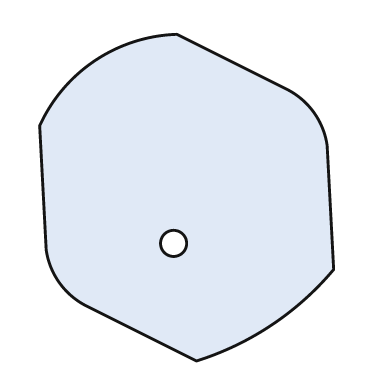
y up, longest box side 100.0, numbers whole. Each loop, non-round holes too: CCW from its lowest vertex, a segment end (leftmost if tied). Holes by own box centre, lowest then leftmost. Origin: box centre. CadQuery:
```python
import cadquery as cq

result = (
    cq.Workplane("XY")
    .moveTo(3.0, -50.0)
    .threePointArc((26.0, -39.0), (45.0, -22.0))
    .lineTo(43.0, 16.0)
    .threePointArc((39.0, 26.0), (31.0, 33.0))
    .lineTo(-3.0, 50.0)
    .threePointArc((-28.0, 42.0), (-45.0, 22.0))
    .lineTo(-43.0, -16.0)
    .threePointArc((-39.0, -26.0), (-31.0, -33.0))
    .close()
    .moveTo(-4.0, -14.0)
    .circle(4.0)
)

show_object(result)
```